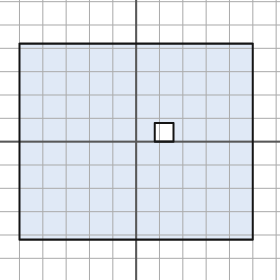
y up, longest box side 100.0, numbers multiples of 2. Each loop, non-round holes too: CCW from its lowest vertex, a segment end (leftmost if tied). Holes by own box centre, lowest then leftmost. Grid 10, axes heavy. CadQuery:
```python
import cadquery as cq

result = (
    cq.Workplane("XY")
    .moveTo(-50.0, -42.0)
    .lineTo(50.0, -42.0)
    .lineTo(50.0, 42.0)
    .lineTo(-50.0, 42.0)
    .close()
    .moveTo(8.0, 0.0)
    .lineTo(16.0, 0.0)
    .lineTo(16.0, 8.0)
    .lineTo(8.0, 8.0)
    .close()
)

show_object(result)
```